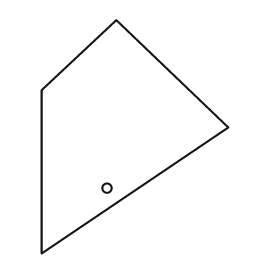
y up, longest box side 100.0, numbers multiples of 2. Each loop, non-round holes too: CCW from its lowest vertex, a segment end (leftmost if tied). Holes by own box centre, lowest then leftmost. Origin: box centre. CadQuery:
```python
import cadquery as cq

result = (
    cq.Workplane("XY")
    .moveTo(-40.0, -50.0)
    .lineTo(40.0, 4.0)
    .lineTo(-8.0, 50.0)
    .lineTo(-40.0, 20.0)
    .close()
    .moveTo(-12.0, -22.0)
    .circle(2.0)
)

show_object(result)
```